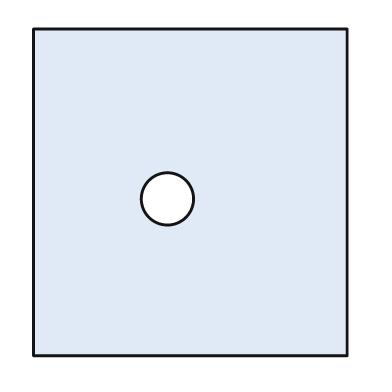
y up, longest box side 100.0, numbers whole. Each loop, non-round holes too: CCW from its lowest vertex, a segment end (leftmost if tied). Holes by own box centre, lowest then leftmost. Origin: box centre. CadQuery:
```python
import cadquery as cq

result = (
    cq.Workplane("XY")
    .moveTo(-48.0, -50.0)
    .lineTo(48.0, -50.0)
    .lineTo(48.0, 50.0)
    .lineTo(-48.0, 50.0)
    .close()
    .moveTo(-7.0, -2.0)
    .circle(8.0)
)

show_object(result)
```